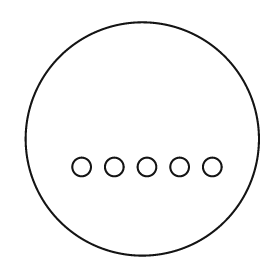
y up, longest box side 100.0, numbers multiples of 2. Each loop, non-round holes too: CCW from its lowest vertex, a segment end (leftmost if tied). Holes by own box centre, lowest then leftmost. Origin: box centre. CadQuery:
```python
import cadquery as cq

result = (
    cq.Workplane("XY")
    .moveTo(0.0, 0.0)
    .circle(50.0)
    .moveTo(-26.0, -12.0)
    .circle(4.0)
    .moveTo(-12.0, -12.0)
    .circle(4.0)
    .moveTo(2.0, -12.0)
    .circle(4.0)
    .moveTo(16.0, -12.0)
    .circle(4.0)
    .moveTo(30.0, -12.0)
    .circle(4.0)
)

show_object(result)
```